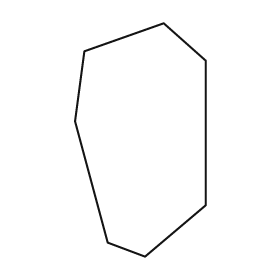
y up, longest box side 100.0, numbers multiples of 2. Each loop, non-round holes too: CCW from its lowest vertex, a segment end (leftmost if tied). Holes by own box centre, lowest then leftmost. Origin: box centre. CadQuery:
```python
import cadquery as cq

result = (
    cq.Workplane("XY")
    .moveTo(2.0, -50.0)
    .lineTo(28.0, -28.0)
    .lineTo(28.0, 34.0)
    .lineTo(10.0, 50.0)
    .lineTo(-24.0, 38.0)
    .lineTo(-28.0, 8.0)
    .lineTo(-14.0, -44.0)
    .close()
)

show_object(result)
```